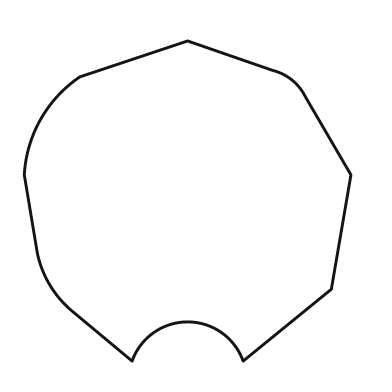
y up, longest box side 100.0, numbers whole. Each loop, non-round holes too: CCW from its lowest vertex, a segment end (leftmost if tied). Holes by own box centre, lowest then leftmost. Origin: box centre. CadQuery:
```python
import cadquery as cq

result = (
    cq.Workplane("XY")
    .moveTo(-17.0, -49.0)
    .threePointArc((0.0, -37.0), (17.0, -49.0))
    .lineTo(44.0, -27.0)
    .lineTo(50.0, 8.0)
    .lineTo(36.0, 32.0)
    .threePointArc((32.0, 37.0), (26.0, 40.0))
    .lineTo(0.0, 49.0)
    .lineTo(-33.0, 38.0)
    .threePointArc((-45.0, 25.0), (-50.0, 8.0))
    .lineTo(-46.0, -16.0)
    .threePointArc((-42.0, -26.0), (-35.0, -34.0))
    .close()
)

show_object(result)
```